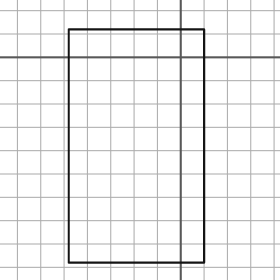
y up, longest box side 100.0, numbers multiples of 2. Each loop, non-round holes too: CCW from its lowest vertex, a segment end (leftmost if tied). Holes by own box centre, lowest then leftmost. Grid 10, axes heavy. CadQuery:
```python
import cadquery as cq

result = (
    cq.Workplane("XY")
    .moveTo(-48.0, -88.0)
    .lineTo(10.0, -88.0)
    .lineTo(10.0, 12.0)
    .lineTo(-48.0, 12.0)
    .close()
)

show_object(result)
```